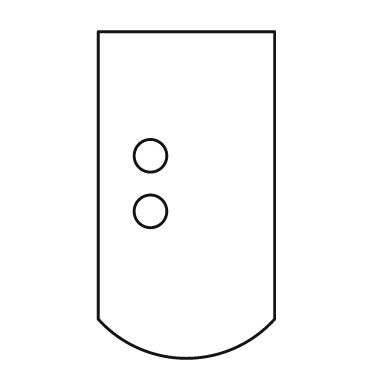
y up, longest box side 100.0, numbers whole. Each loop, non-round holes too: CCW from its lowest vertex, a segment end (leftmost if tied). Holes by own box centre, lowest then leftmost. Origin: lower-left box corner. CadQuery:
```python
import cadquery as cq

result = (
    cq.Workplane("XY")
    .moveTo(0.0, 12.0)
    .threePointArc((27.0, 0.0), (54.0, 12.0))
    .lineTo(54.0, 100.0)
    .lineTo(0.0, 100.0)
    .close()
    .moveTo(16.0, 45.0)
    .circle(5.0)
    .moveTo(16.0, 62.0)
    .circle(5.0)
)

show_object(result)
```